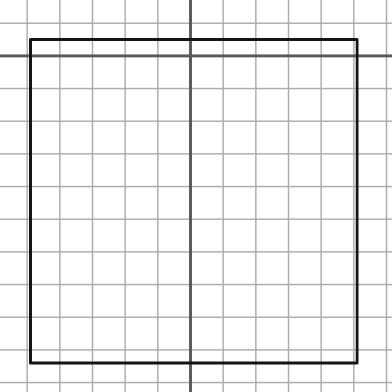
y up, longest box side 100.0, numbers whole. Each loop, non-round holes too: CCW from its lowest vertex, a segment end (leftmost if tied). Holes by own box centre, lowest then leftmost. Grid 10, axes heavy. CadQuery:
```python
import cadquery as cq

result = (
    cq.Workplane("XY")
    .moveTo(-49.0, -94.0)
    .lineTo(51.0, -94.0)
    .lineTo(51.0, 5.0)
    .lineTo(-49.0, 5.0)
    .close()
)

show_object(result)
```